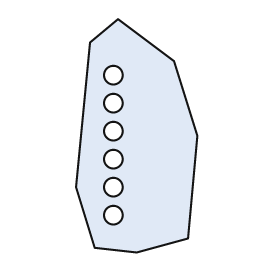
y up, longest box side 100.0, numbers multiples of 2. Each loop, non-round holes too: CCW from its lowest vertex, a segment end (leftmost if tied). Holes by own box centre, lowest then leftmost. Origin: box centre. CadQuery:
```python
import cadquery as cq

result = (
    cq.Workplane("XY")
    .moveTo(0.0, -50.0)
    .lineTo(22.0, -44.0)
    .lineTo(26.0, 0.0)
    .lineTo(16.0, 32.0)
    .lineTo(-8.0, 50.0)
    .lineTo(-20.0, 40.0)
    .lineTo(-26.0, -22.0)
    .lineTo(-18.0, -48.0)
    .close()
    .moveTo(-10.0, -34.0)
    .circle(4.0)
    .moveTo(-10.0, -22.0)
    .circle(4.0)
    .moveTo(-10.0, -10.0)
    .circle(4.0)
    .moveTo(-10.0, 2.0)
    .circle(4.0)
    .moveTo(-10.0, 14.0)
    .circle(4.0)
    .moveTo(-10.0, 26.0)
    .circle(4.0)
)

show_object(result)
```